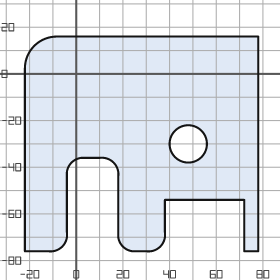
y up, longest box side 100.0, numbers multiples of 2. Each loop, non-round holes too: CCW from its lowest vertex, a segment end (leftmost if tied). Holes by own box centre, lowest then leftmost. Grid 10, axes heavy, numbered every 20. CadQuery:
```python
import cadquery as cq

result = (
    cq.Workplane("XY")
    .moveTo(-22.0, -76.0)
    .lineTo(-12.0, -76.0)
    .threePointArc((-6.0, -74.0), (-4.0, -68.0))
    .lineTo(-4.0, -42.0)
    .threePointArc((-2.0, -38.0), (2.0, -36.0))
    .lineTo(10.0, -36.0)
    .threePointArc((16.0, -38.0), (18.0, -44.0))
    .lineTo(18.0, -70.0)
    .threePointArc((20.0, -74.0), (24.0, -76.0))
    .lineTo(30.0, -76.0)
    .threePointArc((36.0, -74.0), (38.0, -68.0))
    .lineTo(38.0, -54.0)
    .lineTo(72.0, -54.0)
    .lineTo(72.0, -76.0)
    .lineTo(78.0, -76.0)
    .lineTo(78.0, 16.0)
    .lineTo(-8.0, 16.0)
    .threePointArc((-18.0, 12.0), (-22.0, 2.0))
    .close()
    .moveTo(48.0, -30.0)
    .circle(8.0)
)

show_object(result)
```